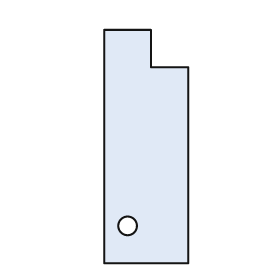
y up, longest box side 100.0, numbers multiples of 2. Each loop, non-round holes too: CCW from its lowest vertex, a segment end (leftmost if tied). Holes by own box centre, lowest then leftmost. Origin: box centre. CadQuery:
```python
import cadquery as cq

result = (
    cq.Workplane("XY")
    .moveTo(-18.0, -50.0)
    .lineTo(18.0, -50.0)
    .lineTo(18.0, 34.0)
    .lineTo(2.0, 34.0)
    .lineTo(2.0, 50.0)
    .lineTo(-18.0, 50.0)
    .close()
    .moveTo(-8.0, -34.0)
    .circle(4.0)
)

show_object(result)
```